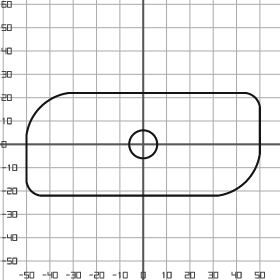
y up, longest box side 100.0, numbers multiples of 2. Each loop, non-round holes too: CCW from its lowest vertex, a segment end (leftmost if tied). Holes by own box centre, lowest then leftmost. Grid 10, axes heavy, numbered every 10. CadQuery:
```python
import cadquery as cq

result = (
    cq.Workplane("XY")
    .moveTo(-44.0, -22.0)
    .lineTo(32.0, -22.0)
    .threePointArc((44.0, -16.0), (50.0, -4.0))
    .lineTo(50.0, 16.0)
    .threePointArc((48.0, 20.0), (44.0, 22.0))
    .lineTo(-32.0, 22.0)
    .threePointArc((-44.0, 16.0), (-50.0, 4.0))
    .lineTo(-50.0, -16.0)
    .threePointArc((-48.0, -20.0), (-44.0, -22.0))
    .close()
    .moveTo(0.0, 0.0)
    .circle(6.0)
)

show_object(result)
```